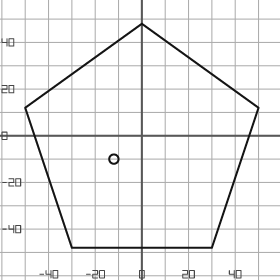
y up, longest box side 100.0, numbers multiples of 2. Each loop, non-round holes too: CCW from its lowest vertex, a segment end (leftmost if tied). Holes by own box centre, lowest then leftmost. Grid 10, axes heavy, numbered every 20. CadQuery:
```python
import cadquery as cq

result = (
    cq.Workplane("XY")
    .moveTo(-30.0, -48.0)
    .lineTo(30.0, -48.0)
    .lineTo(50.0, 12.0)
    .lineTo(0.0, 48.0)
    .lineTo(-50.0, 12.0)
    .close()
    .moveTo(-12.0, -10.0)
    .circle(2.0)
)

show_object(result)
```